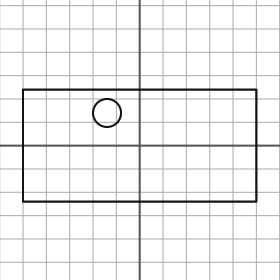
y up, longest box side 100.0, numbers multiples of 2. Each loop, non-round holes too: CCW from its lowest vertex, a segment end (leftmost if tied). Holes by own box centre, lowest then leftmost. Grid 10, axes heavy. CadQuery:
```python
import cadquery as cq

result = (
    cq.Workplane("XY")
    .moveTo(-50.0, -24.0)
    .lineTo(50.0, -24.0)
    .lineTo(50.0, 24.0)
    .lineTo(-50.0, 24.0)
    .close()
    .moveTo(-14.0, 14.0)
    .circle(6.0)
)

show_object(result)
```